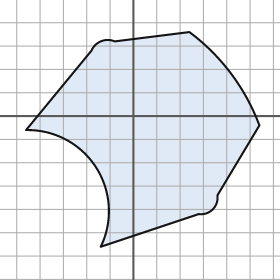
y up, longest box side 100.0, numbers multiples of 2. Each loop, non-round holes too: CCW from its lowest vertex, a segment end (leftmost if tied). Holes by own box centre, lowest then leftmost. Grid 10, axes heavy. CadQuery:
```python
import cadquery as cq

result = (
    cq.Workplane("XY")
    .moveTo(-14.0, -56.0)
    .lineTo(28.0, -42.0)
    .threePointArc((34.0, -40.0), (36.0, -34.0))
    .lineTo(54.0, -4.0)
    .threePointArc((42.0, 18.0), (24.0, 36.0))
    .lineTo(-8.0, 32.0)
    .threePointArc((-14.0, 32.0), (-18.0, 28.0))
    .lineTo(-46.0, -6.0)
    .threePointArc((-16.0, -22.0), (-14.0, -56.0))
    .close()
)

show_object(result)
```